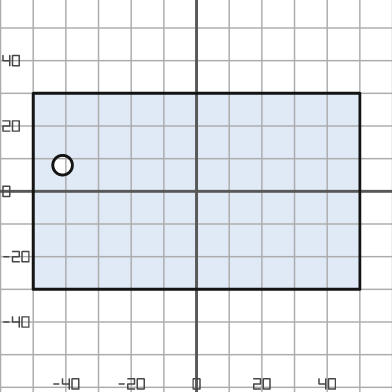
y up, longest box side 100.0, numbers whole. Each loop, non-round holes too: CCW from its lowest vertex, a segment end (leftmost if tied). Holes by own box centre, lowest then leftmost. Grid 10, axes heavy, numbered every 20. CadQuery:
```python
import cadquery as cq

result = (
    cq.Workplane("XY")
    .moveTo(-50.0, -30.0)
    .lineTo(50.0, -30.0)
    .lineTo(50.0, 30.0)
    .lineTo(-50.0, 30.0)
    .close()
    .moveTo(-41.0, 8.0)
    .circle(3.0)
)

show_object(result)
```